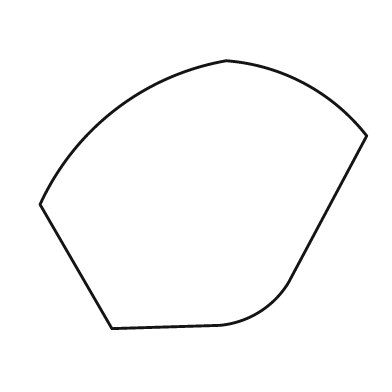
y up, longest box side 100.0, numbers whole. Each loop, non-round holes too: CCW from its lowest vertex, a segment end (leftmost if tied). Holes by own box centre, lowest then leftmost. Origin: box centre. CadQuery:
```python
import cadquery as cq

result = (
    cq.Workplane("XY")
    .moveTo(-28.0, -41.0)
    .lineTo(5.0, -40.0)
    .threePointArc((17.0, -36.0), (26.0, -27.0))
    .lineTo(50.0, 18.0)
    .threePointArc((31.0, 34.0), (7.0, 41.0))
    .threePointArc((-27.0, 26.0), (-50.0, -3.0))
    .close()
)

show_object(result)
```